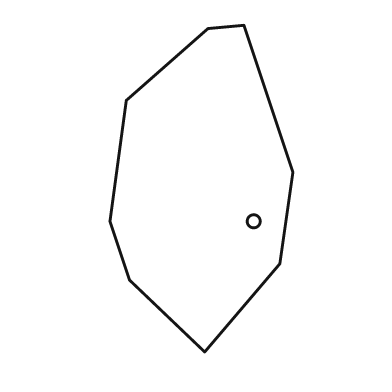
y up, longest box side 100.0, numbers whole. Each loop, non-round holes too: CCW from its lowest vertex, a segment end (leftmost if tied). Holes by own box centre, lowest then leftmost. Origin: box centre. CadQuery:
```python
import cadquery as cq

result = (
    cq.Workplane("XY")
    .moveTo(1.0, -50.0)
    .lineTo(24.0, -23.0)
    .lineTo(28.0, 5.0)
    .lineTo(13.0, 50.0)
    .lineTo(2.0, 49.0)
    .lineTo(-23.0, 27.0)
    .lineTo(-28.0, -10.0)
    .lineTo(-22.0, -28.0)
    .close()
    .moveTo(16.0, -10.0)
    .circle(2.0)
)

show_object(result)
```